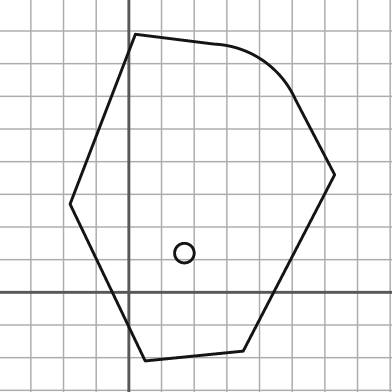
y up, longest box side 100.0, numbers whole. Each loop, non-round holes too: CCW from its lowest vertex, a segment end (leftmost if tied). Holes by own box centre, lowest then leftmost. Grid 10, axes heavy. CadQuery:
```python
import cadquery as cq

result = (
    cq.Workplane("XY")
    .moveTo(5.0, -21.0)
    .lineTo(35.0, -18.0)
    .lineTo(63.0, 36.0)
    .lineTo(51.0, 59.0)
    .threePointArc((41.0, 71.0), (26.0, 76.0))
    .lineTo(2.0, 79.0)
    .lineTo(-18.0, 27.0)
    .close()
    .moveTo(17.0, 12.0)
    .circle(3.0)
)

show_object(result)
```